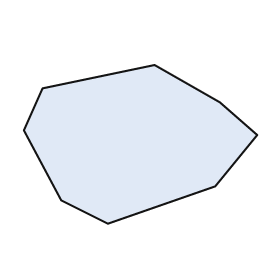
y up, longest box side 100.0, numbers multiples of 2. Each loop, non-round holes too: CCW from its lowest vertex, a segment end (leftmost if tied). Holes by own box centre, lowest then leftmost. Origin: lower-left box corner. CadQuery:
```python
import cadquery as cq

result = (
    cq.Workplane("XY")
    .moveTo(36.0, 0.0)
    .lineTo(82.0, 16.0)
    .lineTo(100.0, 38.0)
    .lineTo(84.0, 52.0)
    .lineTo(56.0, 68.0)
    .lineTo(8.0, 58.0)
    .lineTo(0.0, 40.0)
    .lineTo(16.0, 10.0)
    .close()
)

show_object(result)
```